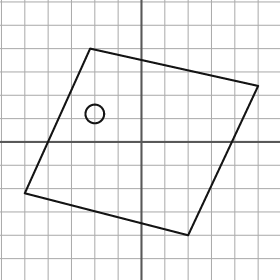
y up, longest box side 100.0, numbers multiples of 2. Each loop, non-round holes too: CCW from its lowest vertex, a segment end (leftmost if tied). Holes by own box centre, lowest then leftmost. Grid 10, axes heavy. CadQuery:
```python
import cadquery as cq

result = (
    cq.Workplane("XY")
    .moveTo(20.0, -40.0)
    .lineTo(50.0, 24.0)
    .lineTo(-22.0, 40.0)
    .lineTo(-50.0, -22.0)
    .close()
    .moveTo(-20.0, 12.0)
    .circle(4.0)
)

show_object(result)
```